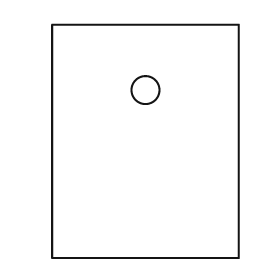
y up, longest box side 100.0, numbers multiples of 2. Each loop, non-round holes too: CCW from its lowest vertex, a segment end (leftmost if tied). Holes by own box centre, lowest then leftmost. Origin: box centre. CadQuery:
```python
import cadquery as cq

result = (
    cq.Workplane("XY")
    .moveTo(-40.0, -50.0)
    .lineTo(40.0, -50.0)
    .lineTo(40.0, 50.0)
    .lineTo(-40.0, 50.0)
    .close()
    .moveTo(0.0, 22.0)
    .circle(6.0)
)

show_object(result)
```